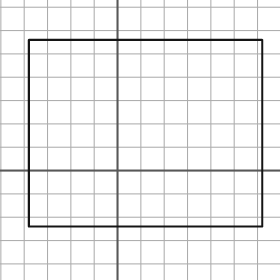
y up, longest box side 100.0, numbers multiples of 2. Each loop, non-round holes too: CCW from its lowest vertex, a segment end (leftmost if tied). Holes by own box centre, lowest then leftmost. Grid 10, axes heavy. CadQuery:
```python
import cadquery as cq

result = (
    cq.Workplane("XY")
    .moveTo(-38.0, -24.0)
    .lineTo(62.0, -24.0)
    .lineTo(62.0, 56.0)
    .lineTo(-38.0, 56.0)
    .close()
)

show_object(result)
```